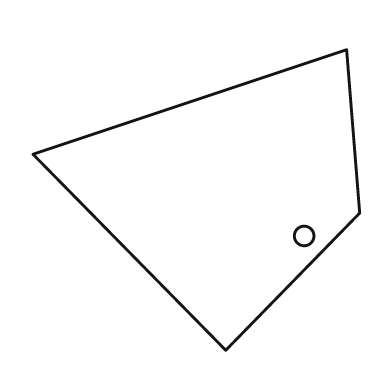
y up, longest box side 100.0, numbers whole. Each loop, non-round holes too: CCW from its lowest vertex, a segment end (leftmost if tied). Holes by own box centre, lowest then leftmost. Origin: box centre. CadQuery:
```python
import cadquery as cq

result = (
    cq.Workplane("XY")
    .moveTo(9.0, -46.0)
    .lineTo(50.0, -4.0)
    .lineTo(46.0, 46.0)
    .lineTo(-50.0, 14.0)
    .close()
    .moveTo(33.0, -11.0)
    .circle(3.0)
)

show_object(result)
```